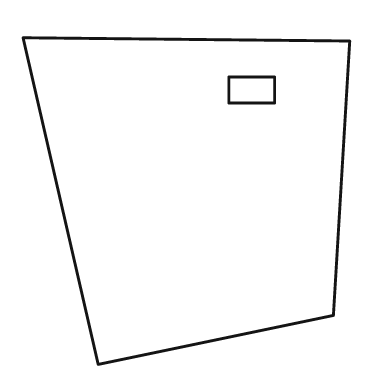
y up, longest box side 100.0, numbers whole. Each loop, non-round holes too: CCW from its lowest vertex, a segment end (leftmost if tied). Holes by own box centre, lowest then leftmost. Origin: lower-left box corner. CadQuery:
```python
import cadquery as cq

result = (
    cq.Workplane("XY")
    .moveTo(23.0, 0.0)
    .lineTo(95.0, 15.0)
    .lineTo(100.0, 99.0)
    .lineTo(0.0, 100.0)
    .close()
    .moveTo(63.0, 80.0)
    .lineTo(77.0, 80.0)
    .lineTo(77.0, 88.0)
    .lineTo(63.0, 88.0)
    .close()
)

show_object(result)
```